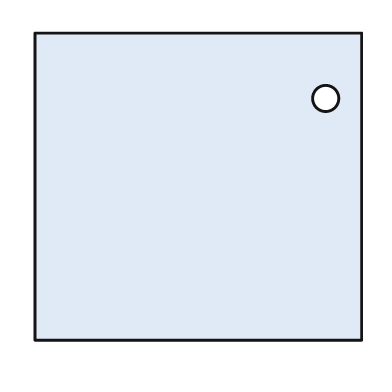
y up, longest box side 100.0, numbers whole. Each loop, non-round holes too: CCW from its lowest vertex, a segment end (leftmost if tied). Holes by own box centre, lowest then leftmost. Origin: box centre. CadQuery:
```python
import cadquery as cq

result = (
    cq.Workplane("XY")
    .moveTo(-50.0, -47.0)
    .lineTo(50.0, -47.0)
    .lineTo(50.0, 47.0)
    .lineTo(-50.0, 47.0)
    .close()
    .moveTo(39.0, 27.0)
    .circle(4.0)
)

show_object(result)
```